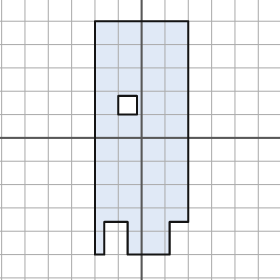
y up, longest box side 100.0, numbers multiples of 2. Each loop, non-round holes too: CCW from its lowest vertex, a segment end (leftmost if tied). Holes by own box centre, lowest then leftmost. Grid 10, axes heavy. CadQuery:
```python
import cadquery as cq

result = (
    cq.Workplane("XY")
    .moveTo(-20.0, -50.0)
    .lineTo(-16.0, -50.0)
    .lineTo(-16.0, -36.0)
    .lineTo(-6.0, -36.0)
    .lineTo(-6.0, -50.0)
    .lineTo(12.0, -50.0)
    .lineTo(12.0, -36.0)
    .lineTo(20.0, -36.0)
    .lineTo(20.0, 50.0)
    .lineTo(-20.0, 50.0)
    .close()
    .moveTo(-10.0, 10.0)
    .lineTo(-2.0, 10.0)
    .lineTo(-2.0, 18.0)
    .lineTo(-10.0, 18.0)
    .close()
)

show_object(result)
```